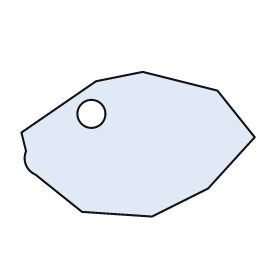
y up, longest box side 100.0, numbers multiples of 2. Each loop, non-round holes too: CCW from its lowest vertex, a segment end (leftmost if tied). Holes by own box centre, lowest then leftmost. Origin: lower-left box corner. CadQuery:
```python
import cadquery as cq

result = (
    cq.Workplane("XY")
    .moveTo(56.0, 0.0)
    .lineTo(80.0, 12.0)
    .lineTo(100.0, 34.0)
    .lineTo(84.0, 54.0)
    .lineTo(52.0, 62.0)
    .lineTo(32.0, 58.0)
    .lineTo(0.0, 36.0)
    .lineTo(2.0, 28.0)
    .threePointArc((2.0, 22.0), (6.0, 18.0))
    .lineTo(26.0, 2.0)
    .close()
    .moveTo(30.0, 44.0)
    .circle(6.0)
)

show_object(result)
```